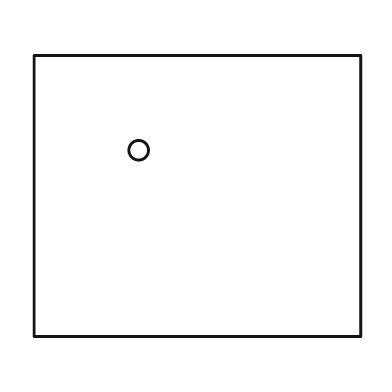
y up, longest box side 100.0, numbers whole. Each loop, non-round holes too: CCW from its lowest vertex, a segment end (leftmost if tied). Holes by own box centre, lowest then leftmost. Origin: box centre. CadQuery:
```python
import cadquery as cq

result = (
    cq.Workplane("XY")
    .moveTo(-50.0, -43.0)
    .lineTo(50.0, -43.0)
    .lineTo(50.0, 43.0)
    .lineTo(-50.0, 43.0)
    .close()
    .moveTo(-18.0, 14.0)
    .circle(3.0)
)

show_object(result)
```